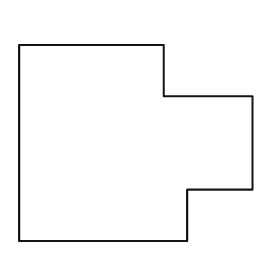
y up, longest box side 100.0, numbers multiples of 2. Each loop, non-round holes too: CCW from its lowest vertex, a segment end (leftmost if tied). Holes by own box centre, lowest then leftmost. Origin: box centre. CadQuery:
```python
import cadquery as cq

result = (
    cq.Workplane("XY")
    .moveTo(-50.0, -42.0)
    .lineTo(22.0, -42.0)
    .lineTo(22.0, -20.0)
    .lineTo(50.0, -20.0)
    .lineTo(50.0, 20.0)
    .lineTo(12.0, 20.0)
    .lineTo(12.0, 42.0)
    .lineTo(-50.0, 42.0)
    .close()
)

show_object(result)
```